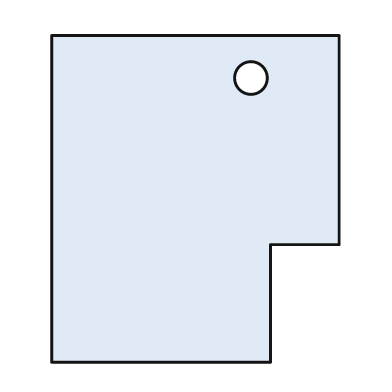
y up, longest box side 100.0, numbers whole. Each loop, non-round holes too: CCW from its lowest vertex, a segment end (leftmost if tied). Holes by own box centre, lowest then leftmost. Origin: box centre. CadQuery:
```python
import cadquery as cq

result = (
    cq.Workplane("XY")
    .moveTo(-44.0, -50.0)
    .lineTo(23.0, -50.0)
    .lineTo(23.0, -14.0)
    .lineTo(44.0, -14.0)
    .lineTo(44.0, 50.0)
    .lineTo(-44.0, 50.0)
    .close()
    .moveTo(17.0, 37.0)
    .circle(5.0)
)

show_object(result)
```